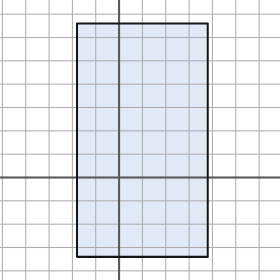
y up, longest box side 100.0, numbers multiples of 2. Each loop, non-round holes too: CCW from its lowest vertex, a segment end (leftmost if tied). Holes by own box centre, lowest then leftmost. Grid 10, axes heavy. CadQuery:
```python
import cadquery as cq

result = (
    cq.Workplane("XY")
    .moveTo(-18.0, -34.0)
    .lineTo(38.0, -34.0)
    .lineTo(38.0, 66.0)
    .lineTo(-18.0, 66.0)
    .close()
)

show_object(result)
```